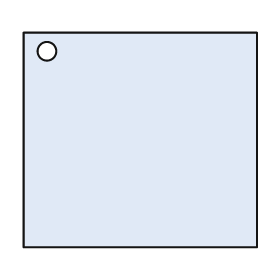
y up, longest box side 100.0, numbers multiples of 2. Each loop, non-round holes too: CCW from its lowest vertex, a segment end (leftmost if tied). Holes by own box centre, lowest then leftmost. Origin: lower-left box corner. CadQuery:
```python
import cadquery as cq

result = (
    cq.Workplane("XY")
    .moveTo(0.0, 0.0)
    .lineTo(100.0, 0.0)
    .lineTo(100.0, 92.0)
    .lineTo(0.0, 92.0)
    .close()
    .moveTo(10.0, 84.0)
    .circle(4.0)
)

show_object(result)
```